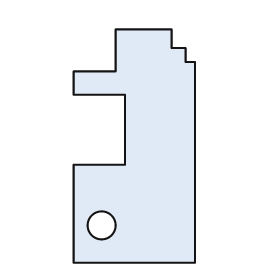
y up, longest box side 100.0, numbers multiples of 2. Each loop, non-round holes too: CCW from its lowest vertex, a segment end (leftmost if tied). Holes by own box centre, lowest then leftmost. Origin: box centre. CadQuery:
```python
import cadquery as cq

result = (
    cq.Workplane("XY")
    .moveTo(-26.0, -50.0)
    .lineTo(26.0, -50.0)
    .lineTo(26.0, 36.0)
    .lineTo(22.0, 36.0)
    .lineTo(22.0, 42.0)
    .lineTo(16.0, 42.0)
    .lineTo(16.0, 50.0)
    .lineTo(-8.0, 50.0)
    .lineTo(-8.0, 32.0)
    .lineTo(-26.0, 32.0)
    .lineTo(-26.0, 22.0)
    .lineTo(-4.0, 22.0)
    .lineTo(-4.0, -8.0)
    .lineTo(-26.0, -8.0)
    .close()
    .moveTo(-14.0, -34.0)
    .circle(6.0)
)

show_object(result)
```